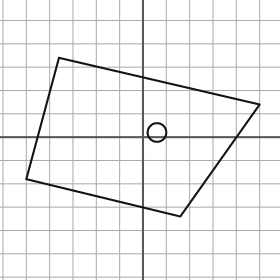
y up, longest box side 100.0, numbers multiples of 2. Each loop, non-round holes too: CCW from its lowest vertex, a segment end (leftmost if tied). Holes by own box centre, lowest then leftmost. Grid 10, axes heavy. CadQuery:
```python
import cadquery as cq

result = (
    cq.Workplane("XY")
    .moveTo(16.0, -34.0)
    .lineTo(50.0, 14.0)
    .lineTo(-36.0, 34.0)
    .lineTo(-50.0, -18.0)
    .close()
    .moveTo(6.0, 2.0)
    .circle(4.0)
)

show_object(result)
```